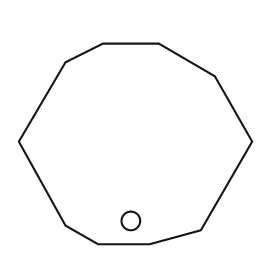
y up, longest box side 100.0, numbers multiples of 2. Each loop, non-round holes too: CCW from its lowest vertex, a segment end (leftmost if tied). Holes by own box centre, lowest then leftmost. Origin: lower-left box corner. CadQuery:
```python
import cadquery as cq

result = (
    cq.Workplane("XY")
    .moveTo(34.0, 0.0)
    .lineTo(56.0, 0.0)
    .lineTo(78.0, 6.0)
    .lineTo(100.0, 44.0)
    .lineTo(84.0, 72.0)
    .lineTo(60.0, 86.0)
    .lineTo(36.0, 86.0)
    .lineTo(20.0, 78.0)
    .lineTo(0.0, 44.0)
    .lineTo(20.0, 8.0)
    .close()
    .moveTo(48.0, 10.0)
    .circle(4.0)
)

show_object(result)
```